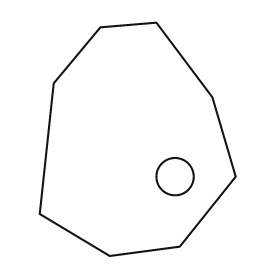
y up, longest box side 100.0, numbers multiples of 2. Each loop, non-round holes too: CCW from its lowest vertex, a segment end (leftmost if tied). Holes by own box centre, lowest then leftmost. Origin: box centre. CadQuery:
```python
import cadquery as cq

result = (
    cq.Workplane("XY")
    .moveTo(-12.0, -50.0)
    .lineTo(18.0, -46.0)
    .lineTo(42.0, -16.0)
    .lineTo(32.0, 18.0)
    .lineTo(8.0, 50.0)
    .lineTo(-16.0, 48.0)
    .lineTo(-36.0, 24.0)
    .lineTo(-42.0, -32.0)
    .close()
    .moveTo(16.0, -16.0)
    .circle(8.0)
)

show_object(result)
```